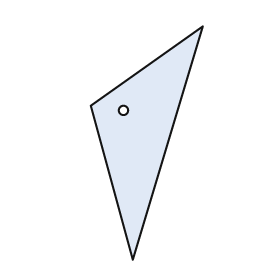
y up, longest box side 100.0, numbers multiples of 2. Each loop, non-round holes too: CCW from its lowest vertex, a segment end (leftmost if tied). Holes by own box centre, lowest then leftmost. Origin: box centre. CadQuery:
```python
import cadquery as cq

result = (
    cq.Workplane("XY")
    .moveTo(-6.0, -50.0)
    .lineTo(24.0, 50.0)
    .lineTo(-24.0, 16.0)
    .close()
    .moveTo(-10.0, 14.0)
    .circle(2.0)
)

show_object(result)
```